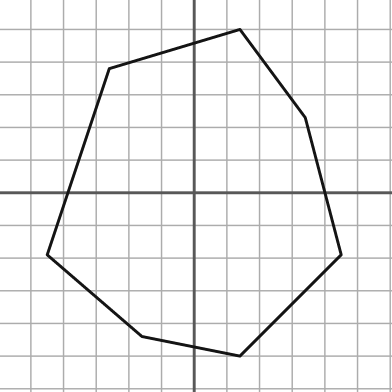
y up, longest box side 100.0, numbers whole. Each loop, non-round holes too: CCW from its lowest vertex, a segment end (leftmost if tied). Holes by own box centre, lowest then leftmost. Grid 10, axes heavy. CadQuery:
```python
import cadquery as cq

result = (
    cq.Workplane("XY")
    .moveTo(14.0, -50.0)
    .lineTo(45.0, -19.0)
    .lineTo(34.0, 23.0)
    .lineTo(14.0, 50.0)
    .lineTo(-26.0, 38.0)
    .lineTo(-45.0, -19.0)
    .lineTo(-16.0, -44.0)
    .close()
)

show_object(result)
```